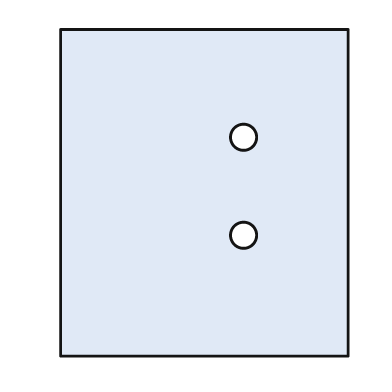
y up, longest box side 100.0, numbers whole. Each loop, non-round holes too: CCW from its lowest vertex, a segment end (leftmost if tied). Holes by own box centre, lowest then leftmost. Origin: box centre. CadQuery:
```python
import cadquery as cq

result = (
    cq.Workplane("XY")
    .moveTo(-44.0, -50.0)
    .lineTo(44.0, -50.0)
    .lineTo(44.0, 50.0)
    .lineTo(-44.0, 50.0)
    .close()
    .moveTo(12.0, -13.0)
    .circle(4.0)
    .moveTo(12.0, 17.0)
    .circle(4.0)
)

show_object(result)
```